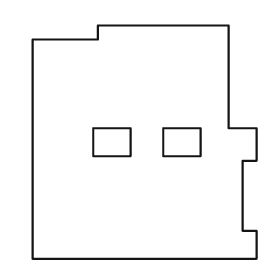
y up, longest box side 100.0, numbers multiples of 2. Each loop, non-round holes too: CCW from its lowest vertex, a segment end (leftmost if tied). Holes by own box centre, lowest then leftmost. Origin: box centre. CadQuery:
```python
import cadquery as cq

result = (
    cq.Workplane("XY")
    .moveTo(-48.0, -50.0)
    .lineTo(48.0, -50.0)
    .lineTo(48.0, -38.0)
    .lineTo(42.0, -38.0)
    .lineTo(42.0, -8.0)
    .lineTo(48.0, -8.0)
    .lineTo(48.0, 6.0)
    .lineTo(36.0, 6.0)
    .lineTo(36.0, 50.0)
    .lineTo(-20.0, 50.0)
    .lineTo(-20.0, 44.0)
    .lineTo(-48.0, 44.0)
    .close()
    .moveTo(-22.0, -6.0)
    .lineTo(-6.0, -6.0)
    .lineTo(-6.0, 6.0)
    .lineTo(-22.0, 6.0)
    .close()
    .moveTo(8.0, -6.0)
    .lineTo(24.0, -6.0)
    .lineTo(24.0, 6.0)
    .lineTo(8.0, 6.0)
    .close()
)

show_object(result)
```